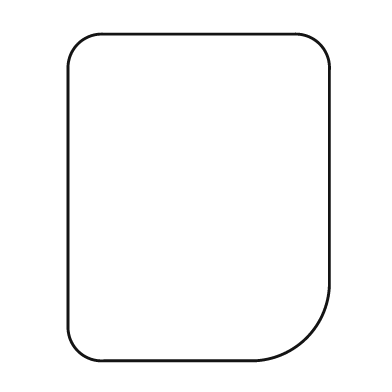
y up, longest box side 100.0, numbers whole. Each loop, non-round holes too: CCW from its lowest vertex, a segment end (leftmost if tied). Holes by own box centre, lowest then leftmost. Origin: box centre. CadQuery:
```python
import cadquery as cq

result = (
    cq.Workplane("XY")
    .moveTo(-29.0, -50.0)
    .lineTo(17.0, -50.0)
    .threePointArc((33.0, -43.0), (40.0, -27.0))
    .lineTo(40.0, 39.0)
    .threePointArc((37.0, 47.0), (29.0, 50.0))
    .lineTo(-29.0, 50.0)
    .threePointArc((-37.0, 47.0), (-40.0, 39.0))
    .lineTo(-40.0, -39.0)
    .threePointArc((-37.0, -47.0), (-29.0, -50.0))
    .close()
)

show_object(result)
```